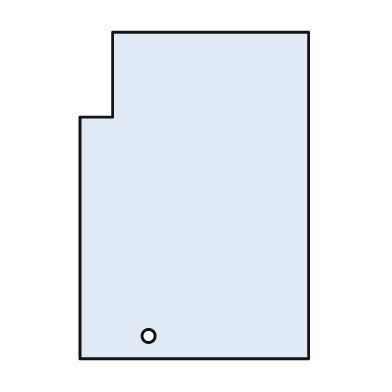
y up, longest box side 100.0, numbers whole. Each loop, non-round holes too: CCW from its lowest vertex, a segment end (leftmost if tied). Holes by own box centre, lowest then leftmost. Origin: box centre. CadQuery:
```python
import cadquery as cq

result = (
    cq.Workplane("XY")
    .moveTo(-35.0, -50.0)
    .lineTo(35.0, -50.0)
    .lineTo(35.0, 50.0)
    .lineTo(-25.0, 50.0)
    .lineTo(-25.0, 24.0)
    .lineTo(-35.0, 24.0)
    .close()
    .moveTo(-14.0, -43.0)
    .circle(2.0)
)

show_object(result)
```